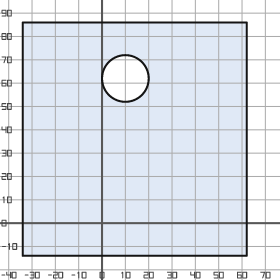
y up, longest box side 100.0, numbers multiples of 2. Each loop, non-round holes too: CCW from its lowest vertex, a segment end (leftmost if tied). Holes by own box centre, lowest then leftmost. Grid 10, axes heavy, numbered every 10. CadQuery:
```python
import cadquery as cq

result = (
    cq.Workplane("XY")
    .moveTo(-34.0, -14.0)
    .lineTo(62.0, -14.0)
    .lineTo(62.0, 86.0)
    .lineTo(-34.0, 86.0)
    .close()
    .moveTo(10.0, 62.0)
    .circle(10.0)
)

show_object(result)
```